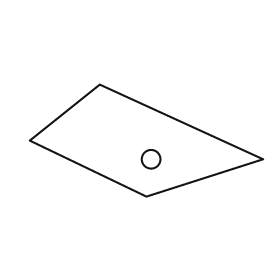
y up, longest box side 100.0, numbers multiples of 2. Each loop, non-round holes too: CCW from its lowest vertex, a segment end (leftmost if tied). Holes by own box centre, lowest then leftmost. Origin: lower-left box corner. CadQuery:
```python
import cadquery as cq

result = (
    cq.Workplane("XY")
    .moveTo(50.0, 0.0)
    .lineTo(100.0, 16.0)
    .lineTo(30.0, 48.0)
    .lineTo(0.0, 24.0)
    .close()
    .moveTo(52.0, 16.0)
    .circle(4.0)
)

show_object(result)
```